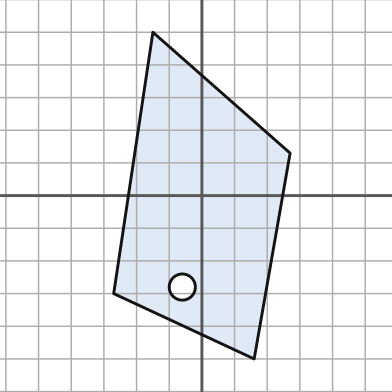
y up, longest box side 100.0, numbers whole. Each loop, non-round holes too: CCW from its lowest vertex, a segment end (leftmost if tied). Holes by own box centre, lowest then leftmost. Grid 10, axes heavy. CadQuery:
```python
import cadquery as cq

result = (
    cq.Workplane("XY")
    .moveTo(16.0, -50.0)
    .lineTo(27.0, 13.0)
    .lineTo(-15.0, 50.0)
    .lineTo(-27.0, -30.0)
    .close()
    .moveTo(-6.0, -28.0)
    .circle(4.0)
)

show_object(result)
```